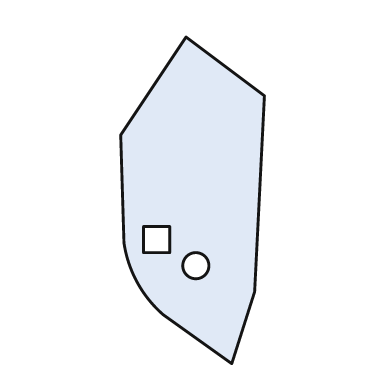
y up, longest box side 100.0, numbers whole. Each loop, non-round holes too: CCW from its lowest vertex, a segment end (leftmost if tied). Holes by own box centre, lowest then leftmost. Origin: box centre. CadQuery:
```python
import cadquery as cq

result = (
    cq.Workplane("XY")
    .moveTo(12.0, -50.0)
    .lineTo(19.0, -28.0)
    .lineTo(22.0, 32.0)
    .lineTo(-2.0, 50.0)
    .lineTo(-22.0, 20.0)
    .lineTo(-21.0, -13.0)
    .threePointArc((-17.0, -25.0), (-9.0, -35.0))
    .close()
    .moveTo(1.0, -20.0)
    .circle(4.0)
    .moveTo(-15.0, -16.0)
    .lineTo(-7.0, -16.0)
    .lineTo(-7.0, -8.0)
    .lineTo(-15.0, -8.0)
    .close()
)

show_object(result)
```